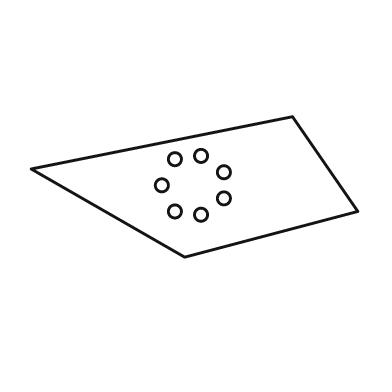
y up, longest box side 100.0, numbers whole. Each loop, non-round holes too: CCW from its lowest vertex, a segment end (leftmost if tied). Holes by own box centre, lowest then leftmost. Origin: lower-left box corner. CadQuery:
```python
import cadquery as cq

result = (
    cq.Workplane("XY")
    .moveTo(47.0, 0.0)
    .lineTo(100.0, 14.0)
    .lineTo(80.0, 43.0)
    .lineTo(0.0, 27.0)
    .close()
    .moveTo(52.0, 13.0)
    .circle(2.0)
    .moveTo(44.0, 14.0)
    .circle(2.0)
    .moveTo(59.0, 18.0)
    .circle(2.0)
    .moveTo(40.0, 22.0)
    .circle(2.0)
    .moveTo(59.0, 26.0)
    .circle(2.0)
    .moveTo(44.0, 30.0)
    .circle(2.0)
    .moveTo(52.0, 31.0)
    .circle(2.0)
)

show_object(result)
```